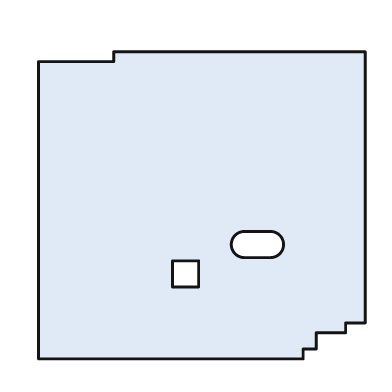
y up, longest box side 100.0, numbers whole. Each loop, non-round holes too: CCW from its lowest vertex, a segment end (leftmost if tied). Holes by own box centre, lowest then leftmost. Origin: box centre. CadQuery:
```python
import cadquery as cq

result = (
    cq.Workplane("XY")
    .moveTo(-50.0, -47.0)
    .lineTo(31.0, -47.0)
    .lineTo(31.0, -44.0)
    .lineTo(35.0, -44.0)
    .lineTo(35.0, -39.0)
    .lineTo(44.0, -39.0)
    .lineTo(44.0, -36.0)
    .lineTo(50.0, -36.0)
    .lineTo(50.0, 47.0)
    .lineTo(-27.0, 47.0)
    .lineTo(-27.0, 44.0)
    .lineTo(-50.0, 44.0)
    .close()
    .moveTo(-9.0, -25.0)
    .lineTo(-1.0, -25.0)
    .lineTo(-1.0, -17.0)
    .lineTo(-9.0, -17.0)
    .close()
    .moveTo(13.0, -16.0)
    .lineTo(21.0, -16.0)
    .threePointArc((25.0, -12.0), (21.0, -8.0))
    .lineTo(13.0, -8.0)
    .threePointArc((9.0, -12.0), (13.0, -16.0))
    .close()
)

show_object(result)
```